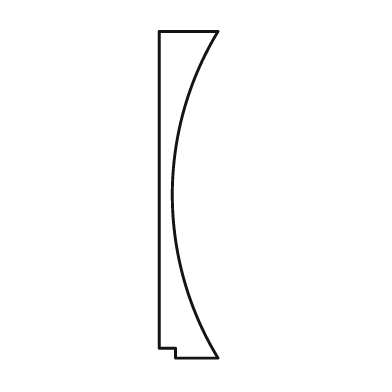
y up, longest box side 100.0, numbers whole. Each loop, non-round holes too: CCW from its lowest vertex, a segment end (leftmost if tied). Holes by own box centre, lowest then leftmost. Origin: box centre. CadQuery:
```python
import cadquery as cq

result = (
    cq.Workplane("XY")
    .moveTo(-4.0, -50.0)
    .lineTo(9.0, -50.0)
    .threePointArc((-5.0, 0.0), (9.0, 50.0))
    .lineTo(-9.0, 50.0)
    .lineTo(-9.0, -47.0)
    .lineTo(-4.0, -47.0)
    .close()
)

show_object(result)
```